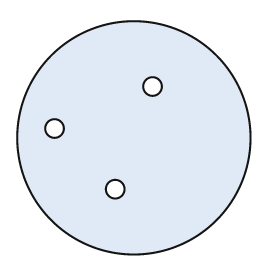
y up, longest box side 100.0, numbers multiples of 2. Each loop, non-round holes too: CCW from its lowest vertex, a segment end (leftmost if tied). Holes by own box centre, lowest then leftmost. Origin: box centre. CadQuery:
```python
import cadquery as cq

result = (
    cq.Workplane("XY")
    .moveTo(0.0, 0.0)
    .circle(50.0)
    .moveTo(-8.0, -22.0)
    .circle(4.0)
    .moveTo(-34.0, 4.0)
    .circle(4.0)
    .moveTo(8.0, 22.0)
    .circle(4.0)
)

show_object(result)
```